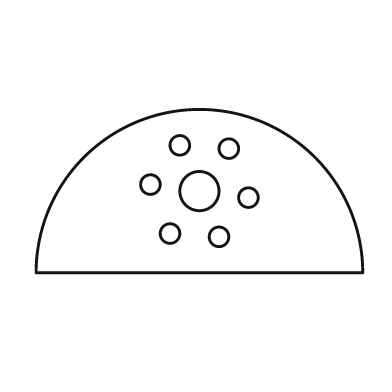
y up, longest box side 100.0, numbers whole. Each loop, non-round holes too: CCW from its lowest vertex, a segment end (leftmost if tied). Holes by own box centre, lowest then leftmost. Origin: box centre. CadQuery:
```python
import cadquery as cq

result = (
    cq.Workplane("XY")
    .moveTo(-50.0, -25.0)
    .lineTo(50.0, -25.0)
    .threePointArc((0.0, 25.0), (-50.0, -25.0))
    .close()
    .moveTo(6.0, -14.0)
    .circle(3.0)
    .moveTo(-9.0, -13.0)
    .circle(3.0)
    .moveTo(15.0, -2.0)
    .circle(3.0)
    .moveTo(0.0, 0.0)
    .circle(6.0)
    .moveTo(-15.0, 2.0)
    .circle(3.0)
    .moveTo(9.0, 13.0)
    .circle(3.0)
    .moveTo(-6.0, 14.0)
    .circle(3.0)
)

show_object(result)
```